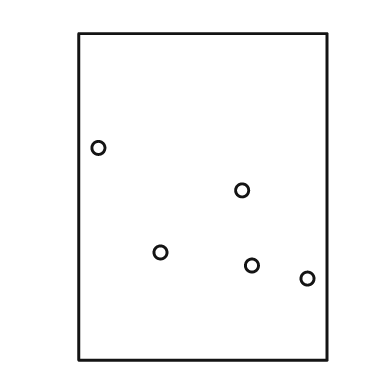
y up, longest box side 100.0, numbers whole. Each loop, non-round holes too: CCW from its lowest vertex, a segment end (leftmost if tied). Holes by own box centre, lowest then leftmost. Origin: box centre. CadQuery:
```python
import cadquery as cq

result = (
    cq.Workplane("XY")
    .moveTo(-38.0, -50.0)
    .lineTo(38.0, -50.0)
    .lineTo(38.0, 50.0)
    .lineTo(-38.0, 50.0)
    .close()
    .moveTo(32.0, -25.0)
    .circle(2.0)
    .moveTo(15.0, -21.0)
    .circle(2.0)
    .moveTo(-13.0, -17.0)
    .circle(2.0)
    .moveTo(12.0, 2.0)
    .circle(2.0)
    .moveTo(-32.0, 15.0)
    .circle(2.0)
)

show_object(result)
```